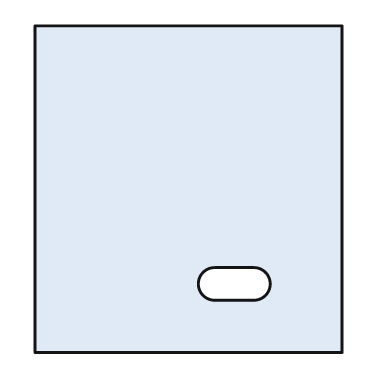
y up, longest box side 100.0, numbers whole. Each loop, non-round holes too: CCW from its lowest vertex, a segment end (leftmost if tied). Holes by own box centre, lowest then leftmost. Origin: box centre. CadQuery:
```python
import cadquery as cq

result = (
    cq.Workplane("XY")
    .moveTo(-47.0, -50.0)
    .lineTo(47.0, -50.0)
    .lineTo(47.0, 50.0)
    .lineTo(-47.0, 50.0)
    .close()
    .moveTo(8.0, -34.0)
    .lineTo(20.0, -34.0)
    .threePointArc((25.0, -29.0), (20.0, -24.0))
    .lineTo(8.0, -24.0)
    .threePointArc((3.0, -29.0), (8.0, -34.0))
    .close()
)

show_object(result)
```